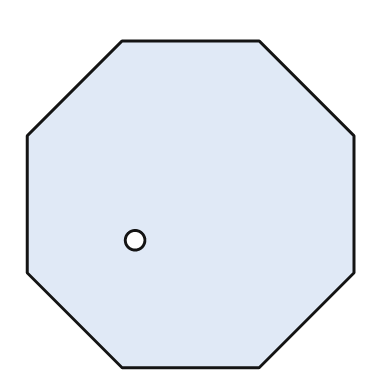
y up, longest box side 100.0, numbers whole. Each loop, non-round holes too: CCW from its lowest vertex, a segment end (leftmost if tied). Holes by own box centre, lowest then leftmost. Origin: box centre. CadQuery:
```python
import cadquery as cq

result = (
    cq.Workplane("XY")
    .moveTo(-21.0, -50.0)
    .lineTo(21.0, -50.0)
    .lineTo(50.0, -21.0)
    .lineTo(50.0, 21.0)
    .lineTo(21.0, 50.0)
    .lineTo(-21.0, 50.0)
    .lineTo(-50.0, 21.0)
    .lineTo(-50.0, -21.0)
    .close()
    .moveTo(-17.0, -11.0)
    .circle(3.0)
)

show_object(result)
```